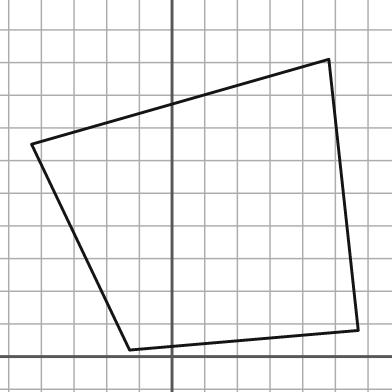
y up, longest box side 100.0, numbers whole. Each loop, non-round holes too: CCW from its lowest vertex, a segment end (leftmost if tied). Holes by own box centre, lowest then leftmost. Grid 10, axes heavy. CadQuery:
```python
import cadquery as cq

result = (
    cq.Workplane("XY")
    .moveTo(-13.0, 2.0)
    .lineTo(57.0, 8.0)
    .lineTo(48.0, 91.0)
    .lineTo(-43.0, 65.0)
    .close()
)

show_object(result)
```